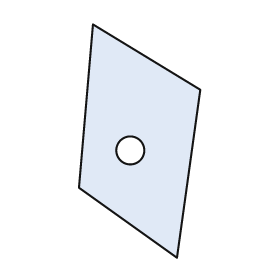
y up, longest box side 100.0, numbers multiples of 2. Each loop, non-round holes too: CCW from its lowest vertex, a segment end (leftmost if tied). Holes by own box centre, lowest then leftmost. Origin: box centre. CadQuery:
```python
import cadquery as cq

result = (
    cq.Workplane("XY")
    .moveTo(16.0, -50.0)
    .lineTo(26.0, 22.0)
    .lineTo(-20.0, 50.0)
    .lineTo(-26.0, -20.0)
    .close()
    .moveTo(-4.0, -4.0)
    .circle(6.0)
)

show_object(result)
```